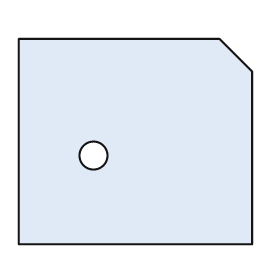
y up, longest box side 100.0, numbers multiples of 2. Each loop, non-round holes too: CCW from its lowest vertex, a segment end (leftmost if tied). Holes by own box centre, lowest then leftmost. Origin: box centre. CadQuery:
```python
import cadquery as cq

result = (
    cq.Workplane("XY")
    .moveTo(-50.0, -44.0)
    .lineTo(50.0, -44.0)
    .lineTo(50.0, 30.0)
    .lineTo(36.0, 44.0)
    .lineTo(-50.0, 44.0)
    .close()
    .moveTo(-18.0, -6.0)
    .circle(6.0)
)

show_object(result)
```